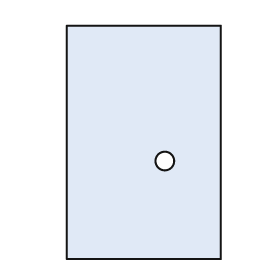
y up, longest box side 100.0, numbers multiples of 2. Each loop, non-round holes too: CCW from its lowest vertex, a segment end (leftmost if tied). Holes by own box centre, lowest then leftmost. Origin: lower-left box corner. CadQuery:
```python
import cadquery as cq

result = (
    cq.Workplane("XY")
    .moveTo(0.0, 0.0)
    .lineTo(66.0, 0.0)
    .lineTo(66.0, 100.0)
    .lineTo(0.0, 100.0)
    .close()
    .moveTo(42.0, 42.0)
    .circle(4.0)
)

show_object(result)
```